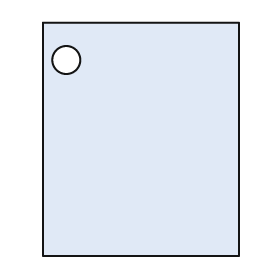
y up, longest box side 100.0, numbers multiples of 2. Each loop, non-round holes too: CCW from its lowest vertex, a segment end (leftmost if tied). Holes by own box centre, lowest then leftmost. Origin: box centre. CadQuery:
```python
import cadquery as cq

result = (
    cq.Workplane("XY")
    .moveTo(-42.0, -50.0)
    .lineTo(42.0, -50.0)
    .lineTo(42.0, 50.0)
    .lineTo(-42.0, 50.0)
    .close()
    .moveTo(-32.0, 34.0)
    .circle(6.0)
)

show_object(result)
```